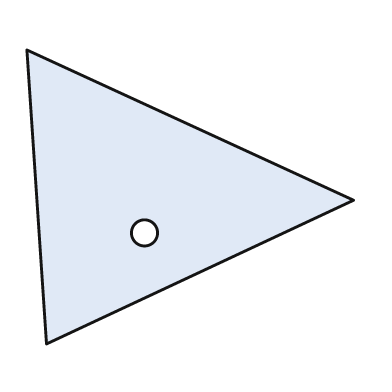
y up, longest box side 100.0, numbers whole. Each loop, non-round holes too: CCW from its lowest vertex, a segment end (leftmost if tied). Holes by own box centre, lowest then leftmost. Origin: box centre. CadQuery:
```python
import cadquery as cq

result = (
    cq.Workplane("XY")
    .moveTo(-44.0, -45.0)
    .lineTo(50.0, -1.0)
    .lineTo(-50.0, 45.0)
    .close()
    .moveTo(-14.0, -11.0)
    .circle(4.0)
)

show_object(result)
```